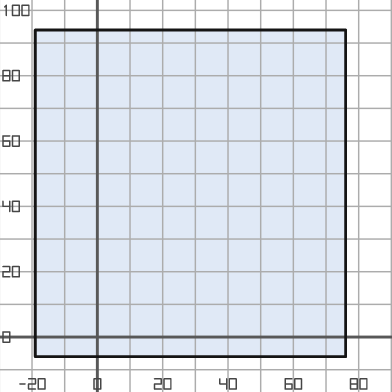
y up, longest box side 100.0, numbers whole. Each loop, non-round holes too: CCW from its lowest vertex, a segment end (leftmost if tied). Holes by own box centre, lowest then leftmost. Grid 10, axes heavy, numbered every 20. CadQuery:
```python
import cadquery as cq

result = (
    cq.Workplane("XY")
    .moveTo(-19.0, -6.0)
    .lineTo(76.0, -6.0)
    .lineTo(76.0, 94.0)
    .lineTo(-19.0, 94.0)
    .close()
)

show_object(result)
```